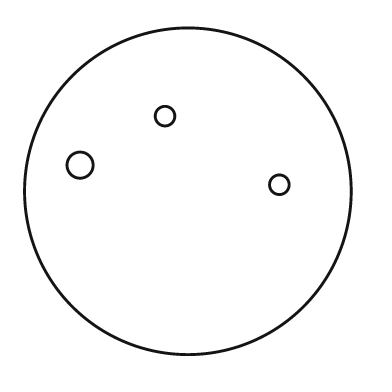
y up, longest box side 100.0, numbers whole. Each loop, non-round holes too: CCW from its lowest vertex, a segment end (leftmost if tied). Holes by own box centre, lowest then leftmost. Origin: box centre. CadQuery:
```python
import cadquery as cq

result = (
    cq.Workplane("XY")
    .moveTo(0.0, 0.0)
    .circle(50.0)
    .moveTo(28.0, 2.0)
    .circle(3.0)
    .moveTo(-33.0, 8.0)
    .circle(4.0)
    .moveTo(-7.0, 23.0)
    .circle(3.0)
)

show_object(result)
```